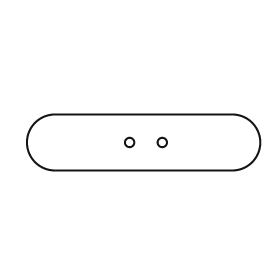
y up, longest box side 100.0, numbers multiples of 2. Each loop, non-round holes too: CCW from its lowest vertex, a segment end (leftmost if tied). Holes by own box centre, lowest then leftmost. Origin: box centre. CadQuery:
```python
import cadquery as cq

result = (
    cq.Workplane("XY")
    .moveTo(-38.0, -12.0)
    .lineTo(38.0, -12.0)
    .threePointArc((50.0, 0.0), (38.0, 12.0))
    .lineTo(-38.0, 12.0)
    .threePointArc((-50.0, 0.0), (-38.0, -12.0))
    .close()
    .moveTo(-6.0, 0.0)
    .circle(2.0)
    .moveTo(8.0, 0.0)
    .circle(2.0)
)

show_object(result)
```